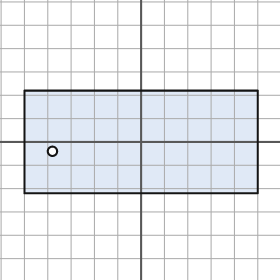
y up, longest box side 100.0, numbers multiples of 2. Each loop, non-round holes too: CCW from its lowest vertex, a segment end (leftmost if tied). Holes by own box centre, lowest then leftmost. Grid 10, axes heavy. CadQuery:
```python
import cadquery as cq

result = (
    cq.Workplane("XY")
    .moveTo(-50.0, -22.0)
    .lineTo(50.0, -22.0)
    .lineTo(50.0, 22.0)
    .lineTo(-50.0, 22.0)
    .close()
    .moveTo(-38.0, -4.0)
    .circle(2.0)
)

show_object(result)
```